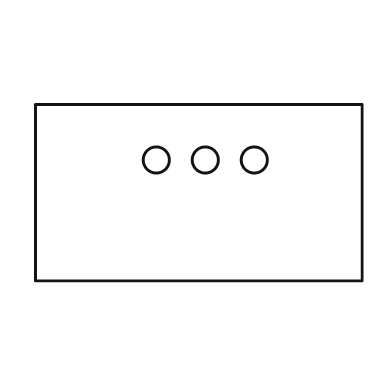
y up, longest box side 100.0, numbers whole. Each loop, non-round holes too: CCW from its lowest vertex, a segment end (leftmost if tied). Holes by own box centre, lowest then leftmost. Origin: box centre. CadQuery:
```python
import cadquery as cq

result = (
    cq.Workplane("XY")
    .moveTo(-50.0, -27.0)
    .lineTo(50.0, -27.0)
    .lineTo(50.0, 27.0)
    .lineTo(-50.0, 27.0)
    .close()
    .moveTo(-13.0, 10.0)
    .circle(4.0)
    .moveTo(2.0, 10.0)
    .circle(4.0)
    .moveTo(17.0, 10.0)
    .circle(4.0)
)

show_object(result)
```